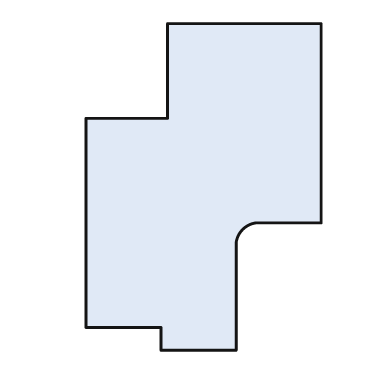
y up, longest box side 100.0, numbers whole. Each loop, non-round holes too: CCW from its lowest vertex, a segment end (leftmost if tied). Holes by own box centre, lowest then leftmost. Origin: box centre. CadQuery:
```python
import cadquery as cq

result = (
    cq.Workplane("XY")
    .moveTo(-13.0, -50.0)
    .lineTo(10.0, -50.0)
    .lineTo(10.0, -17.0)
    .threePointArc((12.0, -13.0), (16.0, -11.0))
    .lineTo(36.0, -11.0)
    .lineTo(36.0, 50.0)
    .lineTo(-11.0, 50.0)
    .lineTo(-11.0, 21.0)
    .lineTo(-36.0, 21.0)
    .lineTo(-36.0, -43.0)
    .lineTo(-13.0, -43.0)
    .close()
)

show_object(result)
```